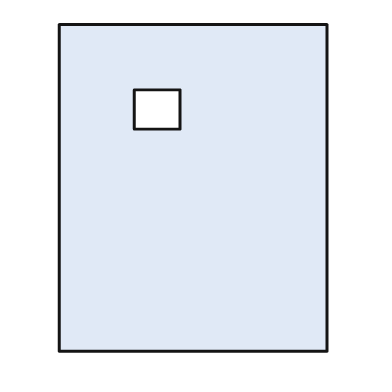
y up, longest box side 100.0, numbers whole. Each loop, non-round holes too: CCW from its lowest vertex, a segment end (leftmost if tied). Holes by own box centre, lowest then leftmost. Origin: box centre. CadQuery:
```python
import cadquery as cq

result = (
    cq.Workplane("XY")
    .moveTo(-41.0, -50.0)
    .lineTo(41.0, -50.0)
    .lineTo(41.0, 50.0)
    .lineTo(-41.0, 50.0)
    .close()
    .moveTo(-18.0, 18.0)
    .lineTo(-4.0, 18.0)
    .lineTo(-4.0, 30.0)
    .lineTo(-18.0, 30.0)
    .close()
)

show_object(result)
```